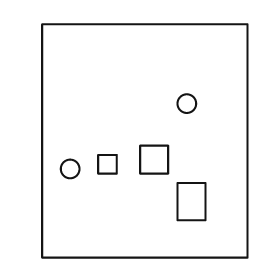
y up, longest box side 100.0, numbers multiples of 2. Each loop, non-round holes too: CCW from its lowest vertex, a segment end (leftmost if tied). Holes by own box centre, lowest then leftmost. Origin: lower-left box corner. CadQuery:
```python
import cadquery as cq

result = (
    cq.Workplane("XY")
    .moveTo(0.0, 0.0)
    .lineTo(88.0, 0.0)
    .lineTo(88.0, 100.0)
    .lineTo(0.0, 100.0)
    .close()
    .moveTo(58.0, 16.0)
    .lineTo(70.0, 16.0)
    .lineTo(70.0, 32.0)
    .lineTo(58.0, 32.0)
    .close()
    .moveTo(12.0, 38.0)
    .circle(4.0)
    .moveTo(24.0, 36.0)
    .lineTo(32.0, 36.0)
    .lineTo(32.0, 44.0)
    .lineTo(24.0, 44.0)
    .close()
    .moveTo(42.0, 36.0)
    .lineTo(54.0, 36.0)
    .lineTo(54.0, 48.0)
    .lineTo(42.0, 48.0)
    .close()
    .moveTo(62.0, 66.0)
    .circle(4.0)
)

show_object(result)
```